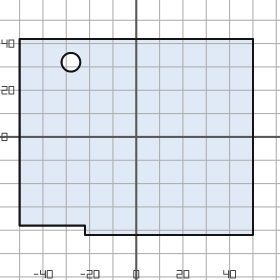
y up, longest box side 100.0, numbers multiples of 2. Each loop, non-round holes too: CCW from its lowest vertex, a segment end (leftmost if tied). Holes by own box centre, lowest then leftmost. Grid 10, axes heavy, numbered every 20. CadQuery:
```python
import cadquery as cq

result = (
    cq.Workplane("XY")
    .moveTo(-22.0, -42.0)
    .lineTo(50.0, -42.0)
    .lineTo(50.0, 42.0)
    .lineTo(-50.0, 42.0)
    .lineTo(-50.0, -38.0)
    .lineTo(-22.0, -38.0)
    .close()
    .moveTo(-28.0, 32.0)
    .circle(4.0)
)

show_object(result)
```